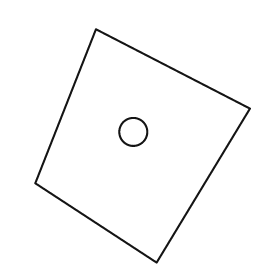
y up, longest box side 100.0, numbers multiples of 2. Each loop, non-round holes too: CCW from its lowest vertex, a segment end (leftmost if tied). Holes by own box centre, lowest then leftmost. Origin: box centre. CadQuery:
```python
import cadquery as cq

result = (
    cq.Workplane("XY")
    .moveTo(6.0, -50.0)
    .lineTo(46.0, 16.0)
    .lineTo(-20.0, 50.0)
    .lineTo(-46.0, -16.0)
    .close()
    .moveTo(-4.0, 6.0)
    .circle(6.0)
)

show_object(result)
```